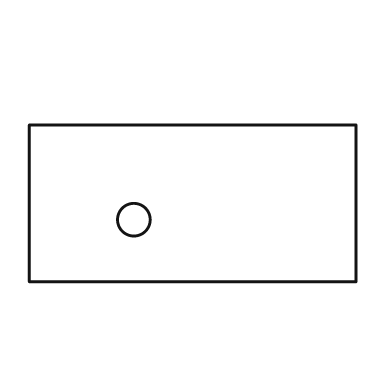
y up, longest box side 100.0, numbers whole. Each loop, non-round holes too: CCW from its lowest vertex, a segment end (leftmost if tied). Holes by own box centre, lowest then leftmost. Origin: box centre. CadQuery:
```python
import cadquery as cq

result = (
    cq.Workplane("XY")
    .moveTo(-50.0, -24.0)
    .lineTo(50.0, -24.0)
    .lineTo(50.0, 24.0)
    .lineTo(-50.0, 24.0)
    .close()
    .moveTo(-18.0, -5.0)
    .circle(5.0)
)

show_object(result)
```